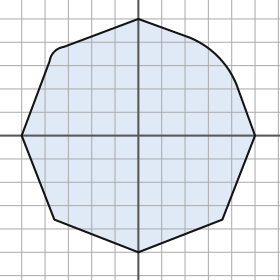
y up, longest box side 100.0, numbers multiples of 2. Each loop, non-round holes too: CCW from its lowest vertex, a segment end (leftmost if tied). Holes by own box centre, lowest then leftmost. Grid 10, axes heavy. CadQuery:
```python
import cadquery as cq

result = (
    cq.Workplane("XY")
    .moveTo(0.0, -50.0)
    .lineTo(36.0, -36.0)
    .lineTo(50.0, 0.0)
    .lineTo(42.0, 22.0)
    .threePointArc((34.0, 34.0), (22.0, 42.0))
    .lineTo(0.0, 50.0)
    .lineTo(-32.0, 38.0)
    .threePointArc((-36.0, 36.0), (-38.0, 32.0))
    .lineTo(-50.0, 0.0)
    .lineTo(-36.0, -36.0)
    .close()
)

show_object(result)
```